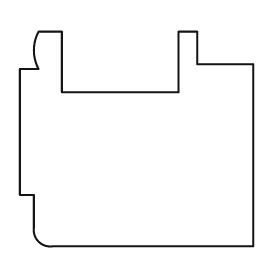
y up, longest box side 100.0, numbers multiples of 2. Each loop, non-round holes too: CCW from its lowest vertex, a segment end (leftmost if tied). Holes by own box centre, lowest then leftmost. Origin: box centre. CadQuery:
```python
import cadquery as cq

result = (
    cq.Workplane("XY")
    .moveTo(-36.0, -46.0)
    .lineTo(50.0, -46.0)
    .lineTo(50.0, 32.0)
    .lineTo(26.0, 32.0)
    .lineTo(26.0, 46.0)
    .lineTo(18.0, 46.0)
    .lineTo(18.0, 20.0)
    .lineTo(-32.0, 20.0)
    .lineTo(-32.0, 46.0)
    .lineTo(-42.0, 46.0)
    .threePointArc((-44.0, 38.0), (-42.0, 30.0))
    .lineTo(-50.0, 30.0)
    .lineTo(-50.0, -24.0)
    .lineTo(-44.0, -24.0)
    .lineTo(-44.0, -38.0)
    .threePointArc((-42.0, -44.0), (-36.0, -46.0))
    .close()
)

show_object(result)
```